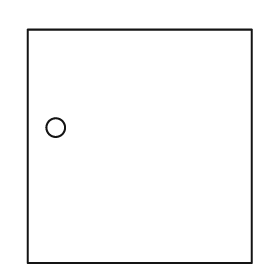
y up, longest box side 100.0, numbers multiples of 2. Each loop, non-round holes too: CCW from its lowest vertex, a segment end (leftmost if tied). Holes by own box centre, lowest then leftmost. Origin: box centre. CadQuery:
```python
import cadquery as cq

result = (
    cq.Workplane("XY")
    .moveTo(-48.0, -50.0)
    .lineTo(48.0, -50.0)
    .lineTo(48.0, 50.0)
    .lineTo(-48.0, 50.0)
    .close()
    .moveTo(-36.0, 8.0)
    .circle(4.0)
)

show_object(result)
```